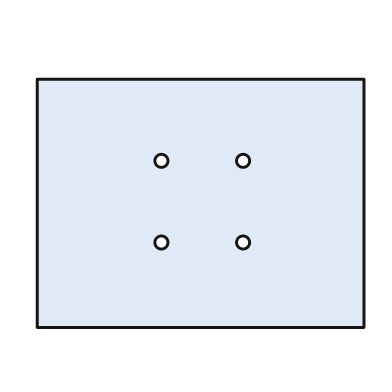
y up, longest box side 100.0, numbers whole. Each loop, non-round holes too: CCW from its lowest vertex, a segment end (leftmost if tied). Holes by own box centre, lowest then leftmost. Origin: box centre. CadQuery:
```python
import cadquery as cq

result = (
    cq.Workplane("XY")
    .moveTo(-50.0, -38.0)
    .lineTo(50.0, -38.0)
    .lineTo(50.0, 38.0)
    .lineTo(-50.0, 38.0)
    .close()
    .moveTo(-12.0, -12.0)
    .circle(2.0)
    .moveTo(13.0, -12.0)
    .circle(2.0)
    .moveTo(-12.0, 13.0)
    .circle(2.0)
    .moveTo(13.0, 13.0)
    .circle(2.0)
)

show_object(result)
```